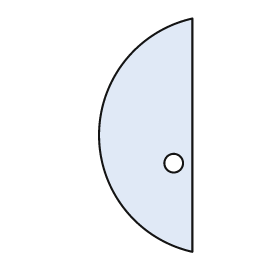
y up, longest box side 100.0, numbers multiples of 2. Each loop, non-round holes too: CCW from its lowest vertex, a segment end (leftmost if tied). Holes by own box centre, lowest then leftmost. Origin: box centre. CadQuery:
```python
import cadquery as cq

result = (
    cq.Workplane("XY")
    .moveTo(20.0, -50.0)
    .lineTo(20.0, 50.0)
    .threePointArc((-20.0, 0.0), (20.0, -50.0))
    .close()
    .moveTo(12.0, -12.0)
    .circle(4.0)
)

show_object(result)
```